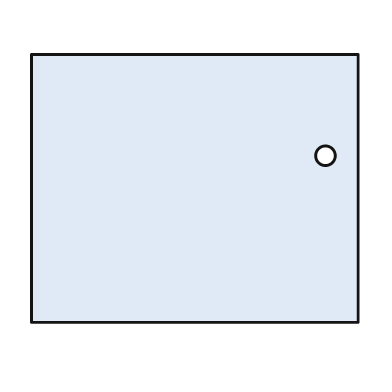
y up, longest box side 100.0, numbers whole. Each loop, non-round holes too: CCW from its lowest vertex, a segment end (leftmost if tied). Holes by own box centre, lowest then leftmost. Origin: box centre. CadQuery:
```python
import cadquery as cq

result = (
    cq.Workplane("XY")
    .moveTo(-50.0, -41.0)
    .lineTo(50.0, -41.0)
    .lineTo(50.0, 41.0)
    .lineTo(-50.0, 41.0)
    .close()
    .moveTo(40.0, 10.0)
    .circle(3.0)
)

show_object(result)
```